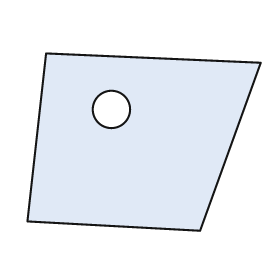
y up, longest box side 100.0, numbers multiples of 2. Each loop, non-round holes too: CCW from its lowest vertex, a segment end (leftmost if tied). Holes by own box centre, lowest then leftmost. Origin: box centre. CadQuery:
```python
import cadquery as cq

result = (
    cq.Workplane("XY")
    .moveTo(24.0, -38.0)
    .lineTo(50.0, 34.0)
    .lineTo(-42.0, 38.0)
    .lineTo(-50.0, -34.0)
    .close()
    .moveTo(-14.0, 14.0)
    .circle(8.0)
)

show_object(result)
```